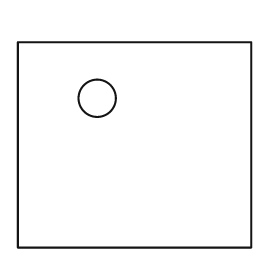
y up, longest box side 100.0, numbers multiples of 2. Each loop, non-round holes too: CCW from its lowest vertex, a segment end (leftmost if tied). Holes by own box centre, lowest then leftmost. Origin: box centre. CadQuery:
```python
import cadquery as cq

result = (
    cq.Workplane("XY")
    .moveTo(-50.0, -44.0)
    .lineTo(50.0, -44.0)
    .lineTo(50.0, 44.0)
    .lineTo(-50.0, 44.0)
    .close()
    .moveTo(-16.0, 20.0)
    .circle(8.0)
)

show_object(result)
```